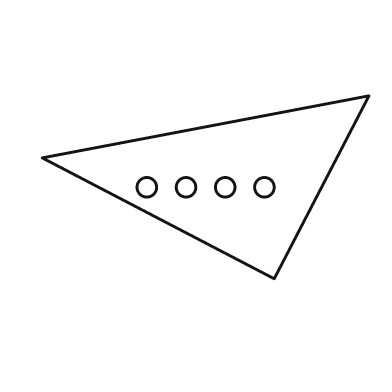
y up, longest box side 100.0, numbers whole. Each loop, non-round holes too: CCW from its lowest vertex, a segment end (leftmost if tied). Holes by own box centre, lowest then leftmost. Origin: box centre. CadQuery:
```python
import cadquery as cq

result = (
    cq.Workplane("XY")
    .moveTo(21.0, -28.0)
    .lineTo(50.0, 28.0)
    .lineTo(-50.0, 9.0)
    .close()
    .moveTo(-18.0, 0.0)
    .circle(3.0)
    .moveTo(-6.0, 0.0)
    .circle(3.0)
    .moveTo(6.0, 0.0)
    .circle(3.0)
    .moveTo(18.0, 0.0)
    .circle(3.0)
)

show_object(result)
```